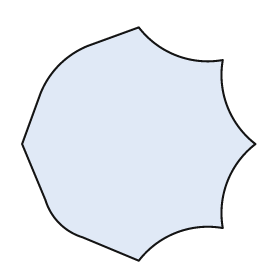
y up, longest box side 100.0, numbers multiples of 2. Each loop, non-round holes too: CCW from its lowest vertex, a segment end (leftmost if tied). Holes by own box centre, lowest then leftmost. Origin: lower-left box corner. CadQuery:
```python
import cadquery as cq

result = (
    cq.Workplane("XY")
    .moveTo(50.0, 0.0)
    .threePointArc((66.0, 12.0), (86.0, 14.0))
    .threePointArc((88.0, 34.0), (100.0, 50.0))
    .threePointArc((88.0, 66.0), (86.0, 86.0))
    .threePointArc((66.0, 88.0), (50.0, 100.0))
    .lineTo(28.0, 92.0)
    .threePointArc((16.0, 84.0), (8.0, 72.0))
    .lineTo(0.0, 50.0)
    .lineTo(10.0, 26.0)
    .threePointArc((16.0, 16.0), (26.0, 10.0))
    .close()
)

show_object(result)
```